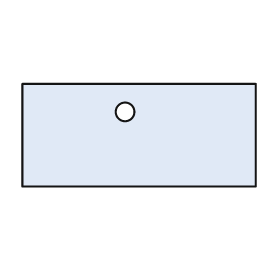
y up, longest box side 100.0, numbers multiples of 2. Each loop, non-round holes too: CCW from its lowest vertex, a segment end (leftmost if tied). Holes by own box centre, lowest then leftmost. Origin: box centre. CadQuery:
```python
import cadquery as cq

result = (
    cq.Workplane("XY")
    .moveTo(-50.0, -22.0)
    .lineTo(50.0, -22.0)
    .lineTo(50.0, 22.0)
    .lineTo(-50.0, 22.0)
    .close()
    .moveTo(-6.0, 10.0)
    .circle(4.0)
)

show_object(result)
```